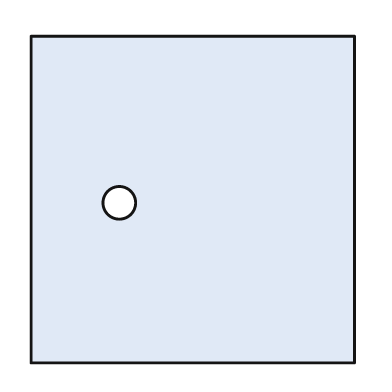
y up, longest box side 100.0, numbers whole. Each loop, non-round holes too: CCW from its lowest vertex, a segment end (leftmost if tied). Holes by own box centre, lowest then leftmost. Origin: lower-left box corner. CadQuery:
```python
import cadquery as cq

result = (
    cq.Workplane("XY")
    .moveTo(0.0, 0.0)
    .lineTo(99.0, 0.0)
    .lineTo(99.0, 100.0)
    .lineTo(0.0, 100.0)
    .close()
    .moveTo(27.0, 49.0)
    .circle(5.0)
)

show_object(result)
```